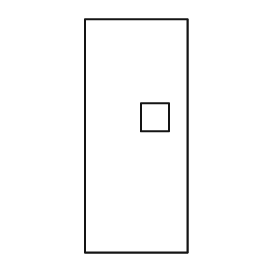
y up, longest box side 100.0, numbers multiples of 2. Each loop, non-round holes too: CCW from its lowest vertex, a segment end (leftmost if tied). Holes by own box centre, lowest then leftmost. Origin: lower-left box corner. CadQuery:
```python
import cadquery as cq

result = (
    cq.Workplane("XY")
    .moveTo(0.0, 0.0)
    .lineTo(44.0, 0.0)
    .lineTo(44.0, 100.0)
    .lineTo(0.0, 100.0)
    .close()
    .moveTo(24.0, 52.0)
    .lineTo(36.0, 52.0)
    .lineTo(36.0, 64.0)
    .lineTo(24.0, 64.0)
    .close()
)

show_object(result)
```